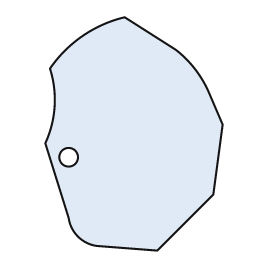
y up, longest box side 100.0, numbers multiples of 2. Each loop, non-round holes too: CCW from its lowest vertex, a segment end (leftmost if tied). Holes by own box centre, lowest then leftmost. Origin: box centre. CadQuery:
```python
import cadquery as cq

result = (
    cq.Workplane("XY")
    .moveTo(10.0, -50.0)
    .lineTo(34.0, -26.0)
    .lineTo(38.0, 4.0)
    .lineTo(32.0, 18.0)
    .threePointArc((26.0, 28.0), (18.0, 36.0))
    .lineTo(-4.0, 50.0)
    .threePointArc((-22.0, 42.0), (-36.0, 28.0))
    .threePointArc((-34.0, 12.0), (-38.0, -4.0))
    .lineTo(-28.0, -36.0)
    .threePointArc((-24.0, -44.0), (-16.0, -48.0))
    .close()
    .moveTo(-28.0, -10.0)
    .circle(4.0)
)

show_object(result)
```